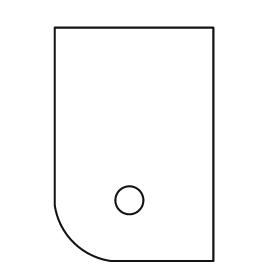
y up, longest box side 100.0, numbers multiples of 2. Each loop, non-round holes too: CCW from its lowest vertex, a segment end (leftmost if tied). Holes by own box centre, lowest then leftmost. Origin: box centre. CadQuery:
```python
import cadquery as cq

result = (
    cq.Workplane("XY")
    .moveTo(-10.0, -50.0)
    .lineTo(34.0, -50.0)
    .lineTo(34.0, 50.0)
    .lineTo(-34.0, 50.0)
    .lineTo(-34.0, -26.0)
    .threePointArc((-26.0, -42.0), (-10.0, -50.0))
    .close()
    .moveTo(-2.0, -24.0)
    .circle(6.0)
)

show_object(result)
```